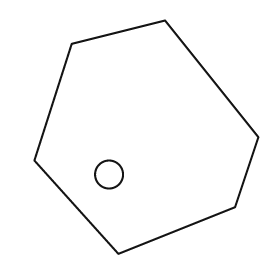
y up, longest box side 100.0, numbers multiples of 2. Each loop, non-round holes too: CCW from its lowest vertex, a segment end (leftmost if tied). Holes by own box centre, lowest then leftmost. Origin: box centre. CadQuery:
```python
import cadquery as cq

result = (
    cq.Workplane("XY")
    .moveTo(-12.0, -50.0)
    .lineTo(38.0, -30.0)
    .lineTo(48.0, 0.0)
    .lineTo(8.0, 50.0)
    .lineTo(-32.0, 40.0)
    .lineTo(-48.0, -10.0)
    .close()
    .moveTo(-16.0, -16.0)
    .circle(6.0)
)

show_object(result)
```